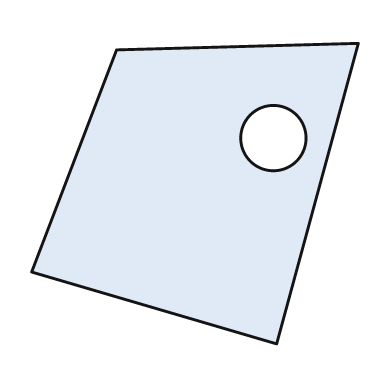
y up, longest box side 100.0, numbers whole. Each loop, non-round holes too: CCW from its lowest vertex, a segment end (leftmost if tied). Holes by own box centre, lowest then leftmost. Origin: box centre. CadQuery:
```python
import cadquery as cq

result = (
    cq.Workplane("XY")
    .moveTo(25.0, -46.0)
    .lineTo(50.0, 46.0)
    .lineTo(-24.0, 44.0)
    .lineTo(-50.0, -24.0)
    .close()
    .moveTo(24.0, 17.0)
    .circle(10.0)
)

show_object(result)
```